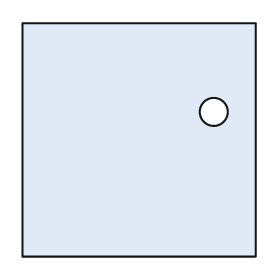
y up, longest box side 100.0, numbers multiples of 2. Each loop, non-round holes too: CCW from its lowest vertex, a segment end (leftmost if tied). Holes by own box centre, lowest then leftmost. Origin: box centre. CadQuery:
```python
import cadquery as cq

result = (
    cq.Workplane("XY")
    .moveTo(-50.0, -50.0)
    .lineTo(50.0, -50.0)
    .lineTo(50.0, 50.0)
    .lineTo(-50.0, 50.0)
    .close()
    .moveTo(32.0, 12.0)
    .circle(6.0)
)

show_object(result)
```